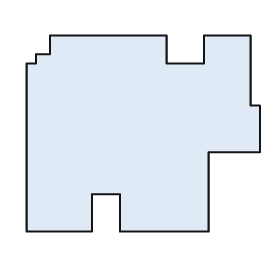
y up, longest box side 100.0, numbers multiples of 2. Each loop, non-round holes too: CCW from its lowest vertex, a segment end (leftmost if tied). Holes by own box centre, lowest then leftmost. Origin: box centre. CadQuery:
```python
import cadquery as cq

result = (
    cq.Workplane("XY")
    .moveTo(-50.0, -42.0)
    .lineTo(-22.0, -42.0)
    .lineTo(-22.0, -26.0)
    .lineTo(-10.0, -26.0)
    .lineTo(-10.0, -42.0)
    .lineTo(28.0, -42.0)
    .lineTo(28.0, -8.0)
    .lineTo(50.0, -8.0)
    .lineTo(50.0, 12.0)
    .lineTo(46.0, 12.0)
    .lineTo(46.0, 42.0)
    .lineTo(26.0, 42.0)
    .lineTo(26.0, 30.0)
    .lineTo(10.0, 30.0)
    .lineTo(10.0, 42.0)
    .lineTo(-40.0, 42.0)
    .lineTo(-40.0, 34.0)
    .lineTo(-46.0, 34.0)
    .lineTo(-46.0, 30.0)
    .lineTo(-50.0, 30.0)
    .close()
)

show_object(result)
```